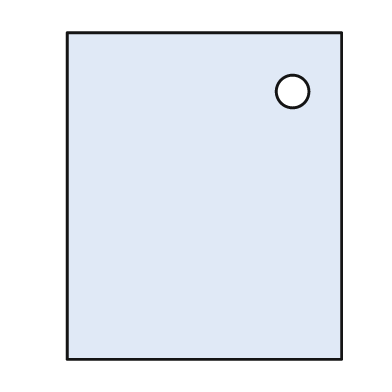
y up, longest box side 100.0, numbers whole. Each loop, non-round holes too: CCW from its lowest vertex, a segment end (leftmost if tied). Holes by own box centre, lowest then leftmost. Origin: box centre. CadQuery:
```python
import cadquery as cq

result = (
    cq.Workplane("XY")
    .moveTo(-42.0, -50.0)
    .lineTo(42.0, -50.0)
    .lineTo(42.0, 50.0)
    .lineTo(-42.0, 50.0)
    .close()
    .moveTo(27.0, 32.0)
    .circle(5.0)
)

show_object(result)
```